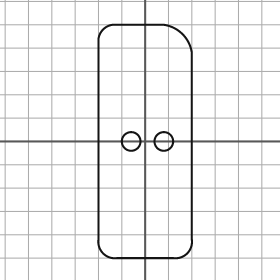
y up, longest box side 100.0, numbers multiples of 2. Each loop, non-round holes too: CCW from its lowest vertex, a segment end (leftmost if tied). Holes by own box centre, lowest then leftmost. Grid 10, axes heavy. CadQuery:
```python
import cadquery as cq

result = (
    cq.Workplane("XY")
    .moveTo(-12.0, -50.0)
    .lineTo(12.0, -50.0)
    .threePointArc((18.0, -48.0), (20.0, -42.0))
    .lineTo(20.0, 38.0)
    .threePointArc((16.0, 46.0), (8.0, 50.0))
    .lineTo(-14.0, 50.0)
    .threePointArc((-18.0, 48.0), (-20.0, 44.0))
    .lineTo(-20.0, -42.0)
    .threePointArc((-18.0, -48.0), (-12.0, -50.0))
    .close()
    .moveTo(-6.0, 0.0)
    .circle(4.0)
    .moveTo(8.0, 0.0)
    .circle(4.0)
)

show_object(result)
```